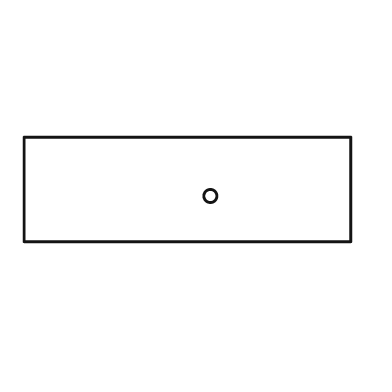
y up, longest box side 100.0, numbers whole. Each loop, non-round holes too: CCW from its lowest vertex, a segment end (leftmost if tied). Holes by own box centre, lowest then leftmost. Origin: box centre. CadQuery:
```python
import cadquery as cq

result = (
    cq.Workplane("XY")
    .moveTo(-50.0, -16.0)
    .lineTo(50.0, -16.0)
    .lineTo(50.0, 16.0)
    .lineTo(-50.0, 16.0)
    .close()
    .moveTo(7.0, -2.0)
    .circle(2.0)
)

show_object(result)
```